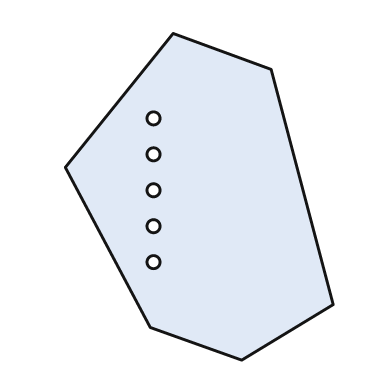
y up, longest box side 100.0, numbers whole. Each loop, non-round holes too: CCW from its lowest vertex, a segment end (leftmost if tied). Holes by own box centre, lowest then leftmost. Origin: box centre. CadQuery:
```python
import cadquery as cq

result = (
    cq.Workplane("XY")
    .moveTo(13.0, -50.0)
    .lineTo(41.0, -33.0)
    .lineTo(22.0, 39.0)
    .lineTo(-8.0, 50.0)
    .lineTo(-41.0, 9.0)
    .lineTo(-15.0, -40.0)
    .close()
    .moveTo(-14.0, -20.0)
    .circle(2.0)
    .moveTo(-14.0, -9.0)
    .circle(2.0)
    .moveTo(-14.0, 2.0)
    .circle(2.0)
    .moveTo(-14.0, 13.0)
    .circle(2.0)
    .moveTo(-14.0, 24.0)
    .circle(2.0)
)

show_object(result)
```